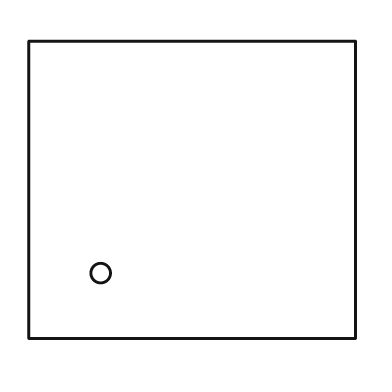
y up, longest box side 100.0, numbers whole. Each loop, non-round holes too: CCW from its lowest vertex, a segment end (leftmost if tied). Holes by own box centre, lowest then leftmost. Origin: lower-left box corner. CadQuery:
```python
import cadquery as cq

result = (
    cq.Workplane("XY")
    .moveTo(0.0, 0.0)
    .lineTo(100.0, 0.0)
    .lineTo(100.0, 91.0)
    .lineTo(0.0, 91.0)
    .close()
    .moveTo(22.0, 20.0)
    .circle(3.0)
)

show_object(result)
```